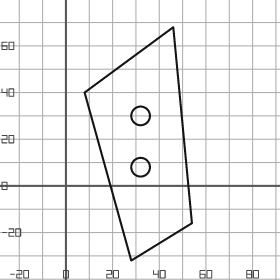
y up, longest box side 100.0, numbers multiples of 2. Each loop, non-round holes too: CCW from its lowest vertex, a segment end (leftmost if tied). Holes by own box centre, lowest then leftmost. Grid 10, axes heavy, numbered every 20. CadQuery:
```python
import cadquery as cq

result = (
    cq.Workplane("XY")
    .moveTo(28.0, -32.0)
    .lineTo(54.0, -16.0)
    .lineTo(46.0, 68.0)
    .lineTo(8.0, 40.0)
    .close()
    .moveTo(32.0, 8.0)
    .circle(4.0)
    .moveTo(32.0, 30.0)
    .circle(4.0)
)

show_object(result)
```